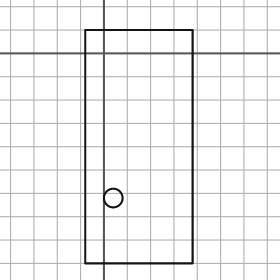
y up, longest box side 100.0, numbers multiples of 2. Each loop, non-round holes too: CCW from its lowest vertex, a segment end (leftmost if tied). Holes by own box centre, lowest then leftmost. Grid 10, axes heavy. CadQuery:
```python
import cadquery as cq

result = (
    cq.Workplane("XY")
    .moveTo(-8.0, -90.0)
    .lineTo(38.0, -90.0)
    .lineTo(38.0, 10.0)
    .lineTo(-8.0, 10.0)
    .close()
    .moveTo(4.0, -62.0)
    .circle(4.0)
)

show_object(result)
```